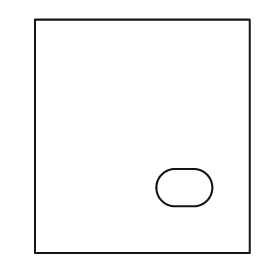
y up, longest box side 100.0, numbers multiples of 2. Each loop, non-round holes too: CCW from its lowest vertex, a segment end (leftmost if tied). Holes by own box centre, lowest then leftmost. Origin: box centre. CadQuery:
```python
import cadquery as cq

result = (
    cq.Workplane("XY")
    .moveTo(-46.0, -50.0)
    .lineTo(46.0, -50.0)
    .lineTo(46.0, 50.0)
    .lineTo(-46.0, 50.0)
    .close()
    .moveTo(14.0, -30.0)
    .lineTo(22.0, -30.0)
    .threePointArc((30.0, -22.0), (22.0, -14.0))
    .lineTo(14.0, -14.0)
    .threePointArc((6.0, -22.0), (14.0, -30.0))
    .close()
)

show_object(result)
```